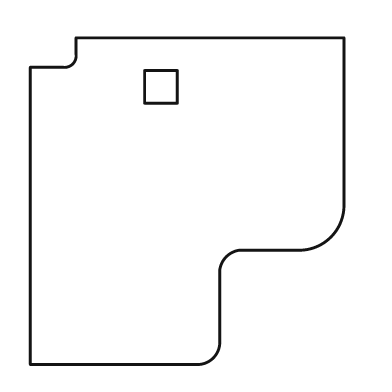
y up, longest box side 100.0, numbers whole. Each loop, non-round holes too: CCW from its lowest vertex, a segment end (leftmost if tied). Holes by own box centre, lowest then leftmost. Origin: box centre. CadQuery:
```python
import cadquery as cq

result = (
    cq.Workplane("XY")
    .moveTo(-48.0, -50.0)
    .lineTo(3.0, -50.0)
    .threePointArc((8.0, -48.0), (10.0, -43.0))
    .lineTo(10.0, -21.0)
    .threePointArc((12.0, -17.0), (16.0, -15.0))
    .lineTo(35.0, -15.0)
    .threePointArc((44.0, -11.0), (48.0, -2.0))
    .lineTo(48.0, 50.0)
    .lineTo(-34.0, 50.0)
    .lineTo(-34.0, 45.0)
    .threePointArc((-35.0, 42.0), (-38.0, 41.0))
    .lineTo(-48.0, 41.0)
    .close()
    .moveTo(-13.0, 30.0)
    .lineTo(-3.0, 30.0)
    .lineTo(-3.0, 40.0)
    .lineTo(-13.0, 40.0)
    .close()
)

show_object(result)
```